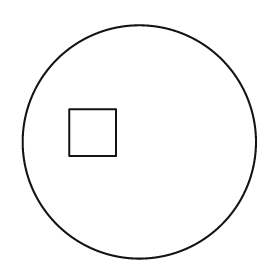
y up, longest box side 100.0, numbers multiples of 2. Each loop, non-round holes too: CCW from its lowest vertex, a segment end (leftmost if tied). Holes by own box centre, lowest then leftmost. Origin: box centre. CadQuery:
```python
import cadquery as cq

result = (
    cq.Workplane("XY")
    .moveTo(0.0, 0.0)
    .circle(50.0)
    .moveTo(-30.0, -6.0)
    .lineTo(-10.0, -6.0)
    .lineTo(-10.0, 14.0)
    .lineTo(-30.0, 14.0)
    .close()
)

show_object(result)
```